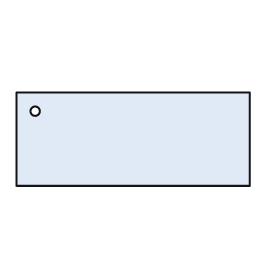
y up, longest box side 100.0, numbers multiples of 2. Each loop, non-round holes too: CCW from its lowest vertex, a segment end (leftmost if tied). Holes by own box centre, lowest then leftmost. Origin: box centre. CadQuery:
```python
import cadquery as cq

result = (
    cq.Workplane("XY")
    .moveTo(-50.0, -20.0)
    .lineTo(50.0, -20.0)
    .lineTo(50.0, 20.0)
    .lineTo(-50.0, 20.0)
    .close()
    .moveTo(-42.0, 12.0)
    .circle(2.0)
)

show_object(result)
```